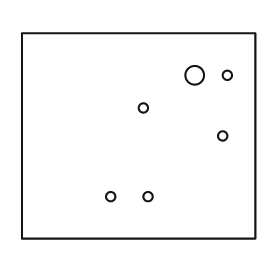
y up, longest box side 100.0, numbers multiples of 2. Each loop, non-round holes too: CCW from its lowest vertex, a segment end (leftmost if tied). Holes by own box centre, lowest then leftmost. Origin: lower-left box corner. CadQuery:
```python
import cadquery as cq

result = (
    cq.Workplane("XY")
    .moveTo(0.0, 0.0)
    .lineTo(100.0, 0.0)
    .lineTo(100.0, 88.0)
    .lineTo(0.0, 88.0)
    .close()
    .moveTo(38.0, 18.0)
    .circle(2.0)
    .moveTo(54.0, 18.0)
    .circle(2.0)
    .moveTo(86.0, 44.0)
    .circle(2.0)
    .moveTo(52.0, 56.0)
    .circle(2.0)
    .moveTo(74.0, 70.0)
    .circle(4.0)
    .moveTo(88.0, 70.0)
    .circle(2.0)
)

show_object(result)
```